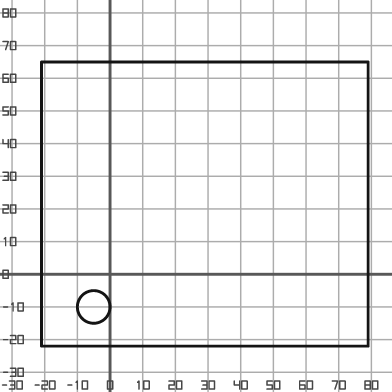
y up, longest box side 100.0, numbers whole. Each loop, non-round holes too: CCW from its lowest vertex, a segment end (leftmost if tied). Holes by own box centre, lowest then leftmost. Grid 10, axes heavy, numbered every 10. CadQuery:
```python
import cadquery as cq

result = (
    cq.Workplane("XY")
    .moveTo(-21.0, -22.0)
    .lineTo(79.0, -22.0)
    .lineTo(79.0, 65.0)
    .lineTo(-21.0, 65.0)
    .close()
    .moveTo(-5.0, -10.0)
    .circle(5.0)
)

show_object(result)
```